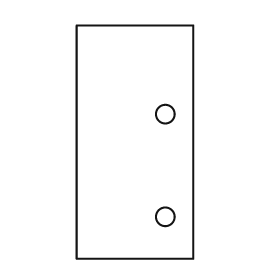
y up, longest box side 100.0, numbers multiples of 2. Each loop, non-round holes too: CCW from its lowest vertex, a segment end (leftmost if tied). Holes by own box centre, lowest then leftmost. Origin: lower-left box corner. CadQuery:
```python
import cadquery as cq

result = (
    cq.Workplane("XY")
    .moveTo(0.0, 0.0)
    .lineTo(50.0, 0.0)
    .lineTo(50.0, 100.0)
    .lineTo(0.0, 100.0)
    .close()
    .moveTo(38.0, 18.0)
    .circle(4.0)
    .moveTo(38.0, 62.0)
    .circle(4.0)
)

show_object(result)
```